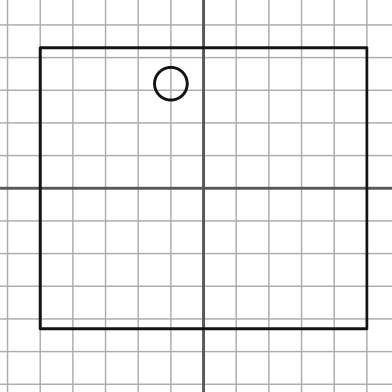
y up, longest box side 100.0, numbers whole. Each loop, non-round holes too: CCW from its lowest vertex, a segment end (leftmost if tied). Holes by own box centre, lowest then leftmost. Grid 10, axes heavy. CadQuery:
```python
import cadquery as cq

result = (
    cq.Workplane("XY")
    .moveTo(-50.0, -43.0)
    .lineTo(50.0, -43.0)
    .lineTo(50.0, 43.0)
    .lineTo(-50.0, 43.0)
    .close()
    .moveTo(-10.0, 32.0)
    .circle(5.0)
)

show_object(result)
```